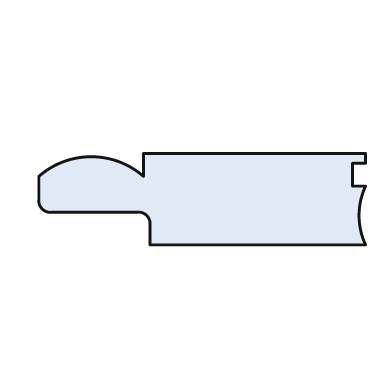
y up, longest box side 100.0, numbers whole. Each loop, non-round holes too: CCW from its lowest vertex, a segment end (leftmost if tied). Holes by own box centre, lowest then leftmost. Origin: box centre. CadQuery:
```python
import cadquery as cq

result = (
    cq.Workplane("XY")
    .moveTo(-16.0, -14.0)
    .lineTo(50.0, -14.0)
    .threePointArc((48.0, -5.0), (50.0, 4.0))
    .lineTo(46.0, 4.0)
    .lineTo(46.0, 11.0)
    .lineTo(50.0, 11.0)
    .lineTo(50.0, 14.0)
    .lineTo(-18.0, 14.0)
    .lineTo(-18.0, 7.0)
    .threePointArc((-34.0, 13.0), (-50.0, 7.0))
    .lineTo(-50.0, 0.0)
    .threePointArc((-49.0, -3.0), (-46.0, -4.0))
    .lineTo(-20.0, -4.0)
    .threePointArc((-17.0, -5.0), (-16.0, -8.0))
    .close()
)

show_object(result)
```